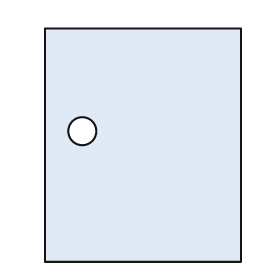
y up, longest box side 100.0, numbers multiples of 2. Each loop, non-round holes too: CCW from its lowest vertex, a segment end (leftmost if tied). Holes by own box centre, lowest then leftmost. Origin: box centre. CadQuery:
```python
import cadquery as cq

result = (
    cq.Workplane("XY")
    .moveTo(-42.0, -50.0)
    .lineTo(42.0, -50.0)
    .lineTo(42.0, 50.0)
    .lineTo(-42.0, 50.0)
    .close()
    .moveTo(-26.0, 6.0)
    .circle(6.0)
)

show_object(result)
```